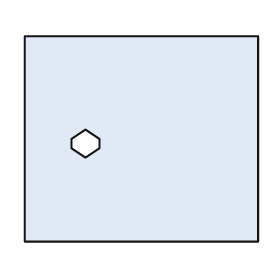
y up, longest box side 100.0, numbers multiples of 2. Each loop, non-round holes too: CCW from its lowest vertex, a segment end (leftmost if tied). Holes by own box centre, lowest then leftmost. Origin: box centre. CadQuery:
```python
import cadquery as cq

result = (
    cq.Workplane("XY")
    .moveTo(-50.0, -44.0)
    .lineTo(50.0, -44.0)
    .lineTo(50.0, 44.0)
    .lineTo(-50.0, 44.0)
    .close()
    .moveTo(-24.0, -8.0)
    .lineTo(-18.0, -4.0)
    .lineTo(-18.0, 0.0)
    .lineTo(-24.0, 4.0)
    .lineTo(-30.0, 0.0)
    .lineTo(-30.0, -4.0)
    .close()
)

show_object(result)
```